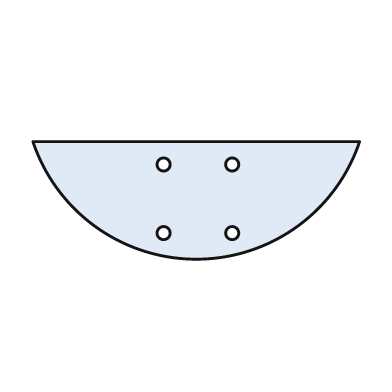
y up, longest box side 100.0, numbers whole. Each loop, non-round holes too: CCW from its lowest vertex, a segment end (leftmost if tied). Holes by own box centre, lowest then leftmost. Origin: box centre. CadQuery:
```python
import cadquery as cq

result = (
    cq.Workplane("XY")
    .moveTo(-50.0, 18.0)
    .threePointArc((0.0, -18.0), (50.0, 18.0))
    .close()
    .moveTo(-10.0, -10.0)
    .circle(2.0)
    .moveTo(11.0, -10.0)
    .circle(2.0)
    .moveTo(-10.0, 11.0)
    .circle(2.0)
    .moveTo(11.0, 11.0)
    .circle(2.0)
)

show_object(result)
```